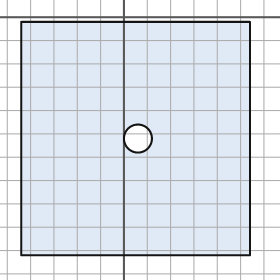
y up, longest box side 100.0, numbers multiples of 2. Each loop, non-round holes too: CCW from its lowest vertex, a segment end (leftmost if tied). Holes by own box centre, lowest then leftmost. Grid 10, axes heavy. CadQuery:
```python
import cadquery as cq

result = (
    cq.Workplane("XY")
    .moveTo(-44.0, -102.0)
    .lineTo(54.0, -102.0)
    .lineTo(54.0, -2.0)
    .lineTo(-44.0, -2.0)
    .close()
    .moveTo(6.0, -52.0)
    .circle(6.0)
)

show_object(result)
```